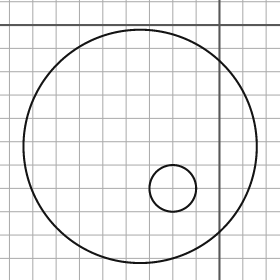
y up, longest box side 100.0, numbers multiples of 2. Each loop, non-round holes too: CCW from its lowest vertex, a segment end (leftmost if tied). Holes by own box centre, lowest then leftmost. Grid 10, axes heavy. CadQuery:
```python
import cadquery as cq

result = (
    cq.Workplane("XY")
    .moveTo(-34.0, -52.0)
    .circle(50.0)
    .moveTo(-20.0, -70.0)
    .circle(10.0)
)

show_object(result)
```